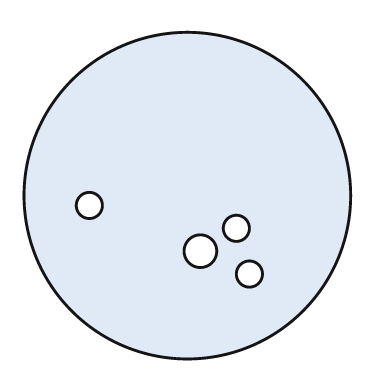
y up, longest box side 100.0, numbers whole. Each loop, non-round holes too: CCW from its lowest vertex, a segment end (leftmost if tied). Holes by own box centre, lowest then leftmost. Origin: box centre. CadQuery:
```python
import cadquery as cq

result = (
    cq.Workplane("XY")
    .moveTo(0.0, 0.0)
    .circle(50.0)
    .moveTo(19.0, -24.0)
    .circle(4.0)
    .moveTo(4.0, -17.0)
    .circle(5.0)
    .moveTo(15.0, -10.0)
    .circle(4.0)
    .moveTo(-30.0, -3.0)
    .circle(4.0)
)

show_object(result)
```